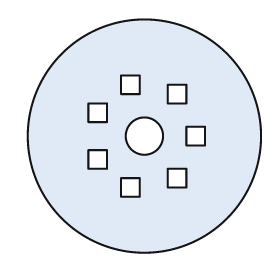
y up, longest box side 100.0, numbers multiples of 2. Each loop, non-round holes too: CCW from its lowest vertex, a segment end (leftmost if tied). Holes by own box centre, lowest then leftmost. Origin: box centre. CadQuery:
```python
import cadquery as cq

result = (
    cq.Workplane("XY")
    .moveTo(0.0, 0.0)
    .circle(50.0)
    .moveTo(-10.0, -26.0)
    .lineTo(-2.0, -26.0)
    .lineTo(-2.0, -18.0)
    .lineTo(-10.0, -18.0)
    .close()
    .moveTo(10.0, -22.0)
    .lineTo(18.0, -22.0)
    .lineTo(18.0, -14.0)
    .lineTo(10.0, -14.0)
    .close()
    .moveTo(-24.0, -14.0)
    .lineTo(-16.0, -14.0)
    .lineTo(-16.0, -6.0)
    .lineTo(-24.0, -6.0)
    .close()
    .moveTo(0.0, 0.0)
    .circle(8.0)
    .moveTo(18.0, -4.0)
    .lineTo(26.0, -4.0)
    .lineTo(26.0, 4.0)
    .lineTo(18.0, 4.0)
    .close()
    .moveTo(-24.0, 6.0)
    .lineTo(-16.0, 6.0)
    .lineTo(-16.0, 14.0)
    .lineTo(-24.0, 14.0)
    .close()
    .moveTo(10.0, 14.0)
    .lineTo(18.0, 14.0)
    .lineTo(18.0, 22.0)
    .lineTo(10.0, 22.0)
    .close()
    .moveTo(-10.0, 18.0)
    .lineTo(-2.0, 18.0)
    .lineTo(-2.0, 26.0)
    .lineTo(-10.0, 26.0)
    .close()
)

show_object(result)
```